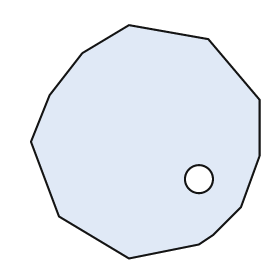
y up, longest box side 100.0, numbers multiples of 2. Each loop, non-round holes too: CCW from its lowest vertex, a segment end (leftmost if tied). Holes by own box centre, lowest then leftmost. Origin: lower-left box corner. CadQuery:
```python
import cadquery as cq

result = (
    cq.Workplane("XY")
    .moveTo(42.0, 0.0)
    .lineTo(72.0, 6.0)
    .lineTo(78.0, 10.0)
    .lineTo(90.0, 22.0)
    .lineTo(98.0, 44.0)
    .lineTo(98.0, 68.0)
    .lineTo(76.0, 94.0)
    .lineTo(42.0, 100.0)
    .lineTo(22.0, 88.0)
    .lineTo(8.0, 70.0)
    .lineTo(0.0, 50.0)
    .lineTo(12.0, 18.0)
    .close()
    .moveTo(72.0, 34.0)
    .circle(6.0)
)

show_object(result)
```